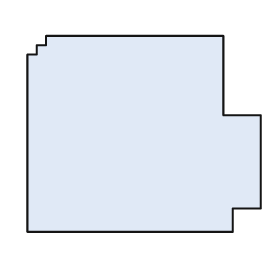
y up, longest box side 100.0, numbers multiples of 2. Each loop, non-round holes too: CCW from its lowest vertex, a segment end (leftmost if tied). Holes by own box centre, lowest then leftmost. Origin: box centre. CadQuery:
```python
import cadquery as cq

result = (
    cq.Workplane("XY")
    .moveTo(-50.0, -42.0)
    .lineTo(38.0, -42.0)
    .lineTo(38.0, -32.0)
    .lineTo(50.0, -32.0)
    .lineTo(50.0, 8.0)
    .lineTo(34.0, 8.0)
    .lineTo(34.0, 42.0)
    .lineTo(-42.0, 42.0)
    .lineTo(-42.0, 38.0)
    .lineTo(-46.0, 38.0)
    .lineTo(-46.0, 34.0)
    .lineTo(-50.0, 34.0)
    .close()
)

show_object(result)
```